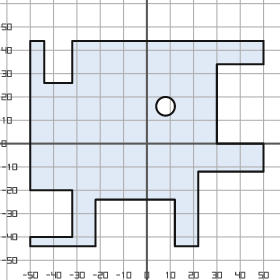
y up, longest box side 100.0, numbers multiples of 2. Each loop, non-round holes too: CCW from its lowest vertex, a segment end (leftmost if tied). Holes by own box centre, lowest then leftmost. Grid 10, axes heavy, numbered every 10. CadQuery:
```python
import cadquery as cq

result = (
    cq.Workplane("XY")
    .moveTo(-50.0, -44.0)
    .lineTo(-22.0, -44.0)
    .lineTo(-22.0, -24.0)
    .lineTo(12.0, -24.0)
    .lineTo(12.0, -44.0)
    .lineTo(22.0, -44.0)
    .lineTo(22.0, -12.0)
    .lineTo(50.0, -12.0)
    .lineTo(50.0, 0.0)
    .lineTo(30.0, 0.0)
    .lineTo(30.0, 34.0)
    .lineTo(50.0, 34.0)
    .lineTo(50.0, 44.0)
    .lineTo(-32.0, 44.0)
    .lineTo(-32.0, 26.0)
    .lineTo(-44.0, 26.0)
    .lineTo(-44.0, 44.0)
    .lineTo(-50.0, 44.0)
    .lineTo(-50.0, -20.0)
    .lineTo(-32.0, -20.0)
    .lineTo(-32.0, -40.0)
    .lineTo(-50.0, -40.0)
    .close()
    .moveTo(8.0, 16.0)
    .circle(4.0)
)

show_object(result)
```